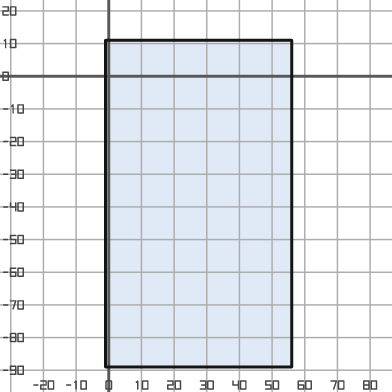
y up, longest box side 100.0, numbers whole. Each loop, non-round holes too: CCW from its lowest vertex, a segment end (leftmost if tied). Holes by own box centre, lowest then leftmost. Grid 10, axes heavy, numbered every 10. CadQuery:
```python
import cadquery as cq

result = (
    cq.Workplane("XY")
    .moveTo(-1.0, -89.0)
    .lineTo(56.0, -89.0)
    .lineTo(56.0, 11.0)
    .lineTo(-1.0, 11.0)
    .close()
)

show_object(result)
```